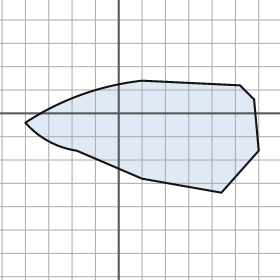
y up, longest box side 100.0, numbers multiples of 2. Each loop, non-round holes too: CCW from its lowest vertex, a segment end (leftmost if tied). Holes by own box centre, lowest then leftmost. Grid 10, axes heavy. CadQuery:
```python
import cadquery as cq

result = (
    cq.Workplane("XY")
    .moveTo(44.0, -34.0)
    .lineTo(60.0, -16.0)
    .lineTo(58.0, 6.0)
    .lineTo(52.0, 12.0)
    .lineTo(10.0, 14.0)
    .threePointArc((-16.0, 8.0), (-40.0, -4.0))
    .threePointArc((-30.0, -12.0), (-18.0, -16.0))
    .lineTo(10.0, -28.0)
    .close()
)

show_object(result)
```